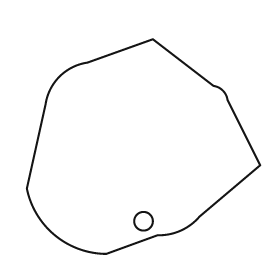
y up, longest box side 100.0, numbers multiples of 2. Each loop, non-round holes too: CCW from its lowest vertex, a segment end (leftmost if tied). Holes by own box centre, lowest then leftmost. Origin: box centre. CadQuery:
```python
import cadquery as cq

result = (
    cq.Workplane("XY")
    .moveTo(-16.0, -46.0)
    .lineTo(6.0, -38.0)
    .threePointArc((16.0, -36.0), (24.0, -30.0))
    .lineTo(50.0, -8.0)
    .lineTo(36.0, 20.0)
    .threePointArc((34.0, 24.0), (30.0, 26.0))
    .lineTo(4.0, 46.0)
    .lineTo(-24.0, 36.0)
    .threePointArc((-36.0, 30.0), (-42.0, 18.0))
    .lineTo(-50.0, -18.0)
    .threePointArc((-38.0, -38.0), (-16.0, -46.0))
    .close()
    .moveTo(0.0, -32.0)
    .circle(4.0)
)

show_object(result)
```